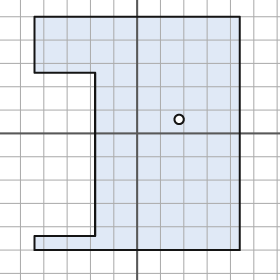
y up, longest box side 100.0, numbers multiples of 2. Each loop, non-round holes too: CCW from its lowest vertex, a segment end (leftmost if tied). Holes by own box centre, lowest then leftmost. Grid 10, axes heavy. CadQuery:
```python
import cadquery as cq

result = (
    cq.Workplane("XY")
    .moveTo(-44.0, -50.0)
    .lineTo(44.0, -50.0)
    .lineTo(44.0, 50.0)
    .lineTo(-44.0, 50.0)
    .lineTo(-44.0, 26.0)
    .lineTo(-18.0, 26.0)
    .lineTo(-18.0, -44.0)
    .lineTo(-44.0, -44.0)
    .close()
    .moveTo(18.0, 6.0)
    .circle(2.0)
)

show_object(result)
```